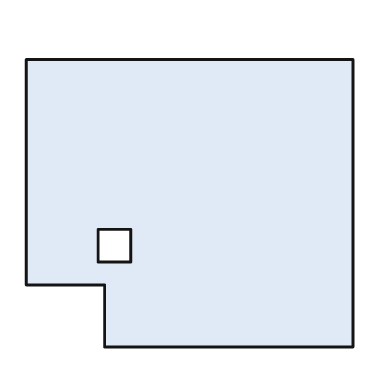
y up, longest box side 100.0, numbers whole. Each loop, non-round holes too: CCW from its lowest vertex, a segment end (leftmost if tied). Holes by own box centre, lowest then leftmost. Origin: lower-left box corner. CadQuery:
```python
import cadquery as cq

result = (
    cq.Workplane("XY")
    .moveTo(24.0, 0.0)
    .lineTo(100.0, 0.0)
    .lineTo(100.0, 88.0)
    .lineTo(0.0, 88.0)
    .lineTo(0.0, 19.0)
    .lineTo(24.0, 19.0)
    .close()
    .moveTo(22.0, 26.0)
    .lineTo(32.0, 26.0)
    .lineTo(32.0, 36.0)
    .lineTo(22.0, 36.0)
    .close()
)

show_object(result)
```